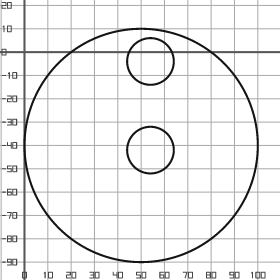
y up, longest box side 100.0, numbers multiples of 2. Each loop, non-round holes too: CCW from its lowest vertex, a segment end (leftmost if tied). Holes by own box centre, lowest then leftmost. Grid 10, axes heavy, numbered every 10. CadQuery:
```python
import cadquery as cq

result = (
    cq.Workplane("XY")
    .moveTo(50.0, -40.0)
    .circle(50.0)
    .moveTo(54.0, -42.0)
    .circle(10.0)
    .moveTo(54.0, -4.0)
    .circle(10.0)
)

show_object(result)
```